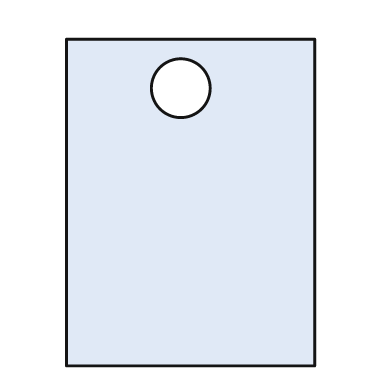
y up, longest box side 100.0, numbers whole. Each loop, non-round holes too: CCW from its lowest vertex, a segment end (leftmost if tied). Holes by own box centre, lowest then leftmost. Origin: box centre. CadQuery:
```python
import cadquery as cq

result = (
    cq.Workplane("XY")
    .moveTo(-38.0, -50.0)
    .lineTo(38.0, -50.0)
    .lineTo(38.0, 50.0)
    .lineTo(-38.0, 50.0)
    .close()
    .moveTo(-3.0, 35.0)
    .circle(9.0)
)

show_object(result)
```